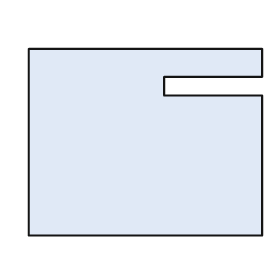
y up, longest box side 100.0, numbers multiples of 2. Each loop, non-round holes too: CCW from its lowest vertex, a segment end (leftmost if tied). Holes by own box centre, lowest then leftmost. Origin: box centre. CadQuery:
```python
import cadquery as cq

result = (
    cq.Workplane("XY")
    .moveTo(-50.0, -40.0)
    .lineTo(50.0, -40.0)
    .lineTo(50.0, 20.0)
    .lineTo(8.0, 20.0)
    .lineTo(8.0, 28.0)
    .lineTo(50.0, 28.0)
    .lineTo(50.0, 40.0)
    .lineTo(-50.0, 40.0)
    .close()
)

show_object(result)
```